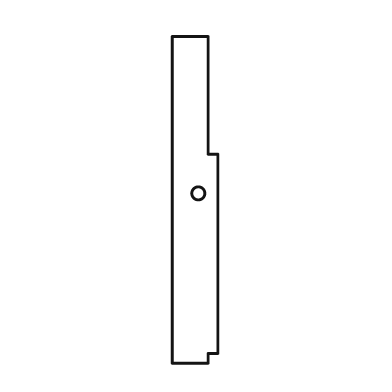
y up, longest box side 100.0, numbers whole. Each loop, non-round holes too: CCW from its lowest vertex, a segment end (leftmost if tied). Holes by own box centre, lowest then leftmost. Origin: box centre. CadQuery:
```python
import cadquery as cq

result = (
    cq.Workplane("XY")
    .moveTo(-7.0, -50.0)
    .lineTo(4.0, -50.0)
    .lineTo(4.0, -47.0)
    .lineTo(7.0, -47.0)
    .lineTo(7.0, 14.0)
    .lineTo(4.0, 14.0)
    .lineTo(4.0, 50.0)
    .lineTo(-7.0, 50.0)
    .close()
    .moveTo(1.0, 2.0)
    .circle(2.0)
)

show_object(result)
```